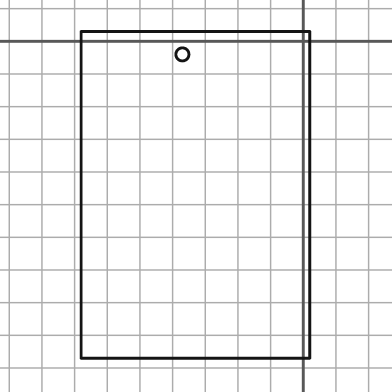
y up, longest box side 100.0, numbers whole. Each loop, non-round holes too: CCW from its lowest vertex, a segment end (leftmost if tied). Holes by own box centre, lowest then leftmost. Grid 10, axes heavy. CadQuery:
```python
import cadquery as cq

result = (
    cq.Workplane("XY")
    .moveTo(-68.0, -97.0)
    .lineTo(2.0, -97.0)
    .lineTo(2.0, 3.0)
    .lineTo(-68.0, 3.0)
    .close()
    .moveTo(-37.0, -4.0)
    .circle(2.0)
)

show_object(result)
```